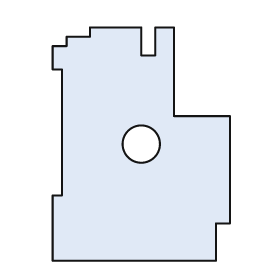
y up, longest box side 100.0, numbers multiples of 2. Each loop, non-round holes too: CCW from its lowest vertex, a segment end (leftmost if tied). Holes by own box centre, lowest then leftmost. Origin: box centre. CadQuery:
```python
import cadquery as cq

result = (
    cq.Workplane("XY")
    .moveTo(-38.0, -50.0)
    .lineTo(32.0, -50.0)
    .lineTo(32.0, -34.0)
    .lineTo(38.0, -34.0)
    .lineTo(38.0, 12.0)
    .lineTo(14.0, 12.0)
    .lineTo(14.0, 50.0)
    .lineTo(6.0, 50.0)
    .lineTo(6.0, 38.0)
    .lineTo(0.0, 38.0)
    .lineTo(0.0, 50.0)
    .lineTo(-22.0, 50.0)
    .lineTo(-22.0, 46.0)
    .lineTo(-32.0, 46.0)
    .lineTo(-32.0, 42.0)
    .lineTo(-38.0, 42.0)
    .lineTo(-38.0, 32.0)
    .lineTo(-34.0, 32.0)
    .lineTo(-34.0, -22.0)
    .lineTo(-38.0, -22.0)
    .close()
    .moveTo(0.0, 0.0)
    .circle(8.0)
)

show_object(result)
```